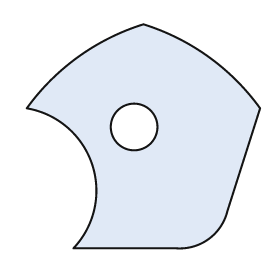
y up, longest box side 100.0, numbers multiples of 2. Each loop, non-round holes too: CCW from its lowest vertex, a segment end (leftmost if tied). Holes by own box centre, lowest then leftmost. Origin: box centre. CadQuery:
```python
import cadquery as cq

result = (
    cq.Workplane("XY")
    .moveTo(-30.0, -48.0)
    .lineTo(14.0, -48.0)
    .threePointArc((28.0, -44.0), (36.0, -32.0))
    .lineTo(50.0, 12.0)
    .threePointArc((28.0, 34.0), (0.0, 48.0))
    .threePointArc((-28.0, 34.0), (-50.0, 12.0))
    .threePointArc((-22.0, -12.0), (-30.0, -48.0))
    .close()
    .moveTo(-4.0, 4.0)
    .circle(10.0)
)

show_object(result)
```